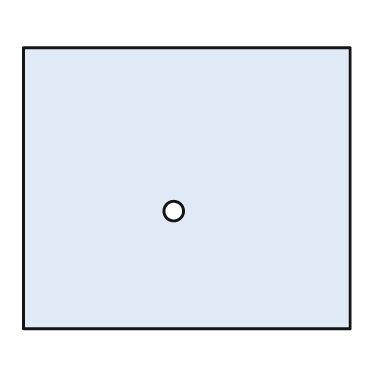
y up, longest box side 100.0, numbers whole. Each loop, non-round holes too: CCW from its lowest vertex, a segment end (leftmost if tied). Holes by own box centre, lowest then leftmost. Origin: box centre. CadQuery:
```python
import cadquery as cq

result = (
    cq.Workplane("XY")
    .moveTo(-50.0, -43.0)
    .lineTo(50.0, -43.0)
    .lineTo(50.0, 43.0)
    .lineTo(-50.0, 43.0)
    .close()
    .moveTo(-4.0, -7.0)
    .circle(3.0)
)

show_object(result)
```